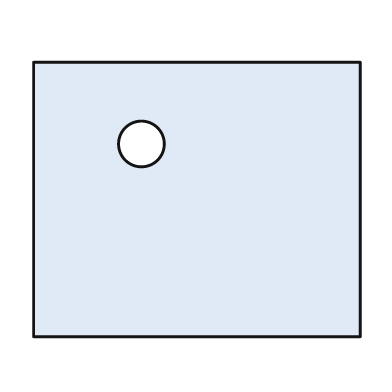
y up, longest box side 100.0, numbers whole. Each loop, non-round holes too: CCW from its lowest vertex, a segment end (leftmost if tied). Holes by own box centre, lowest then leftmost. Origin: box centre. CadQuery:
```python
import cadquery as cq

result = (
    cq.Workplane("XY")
    .moveTo(-50.0, -42.0)
    .lineTo(50.0, -42.0)
    .lineTo(50.0, 42.0)
    .lineTo(-50.0, 42.0)
    .close()
    .moveTo(-17.0, 17.0)
    .circle(7.0)
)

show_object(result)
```